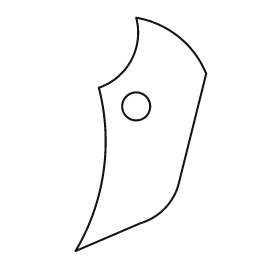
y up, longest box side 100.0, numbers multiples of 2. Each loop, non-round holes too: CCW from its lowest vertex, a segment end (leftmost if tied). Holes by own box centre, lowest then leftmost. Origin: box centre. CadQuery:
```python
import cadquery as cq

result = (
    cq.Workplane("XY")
    .moveTo(-28.0, -50.0)
    .lineTo(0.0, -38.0)
    .threePointArc((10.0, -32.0), (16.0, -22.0))
    .lineTo(28.0, 26.0)
    .threePointArc((16.0, 42.0), (-2.0, 50.0))
    .threePointArc((-4.0, 32.0), (-18.0, 20.0))
    .threePointArc((-16.0, -16.0), (-28.0, -50.0))
    .close()
    .moveTo(-2.0, 12.0)
    .circle(6.0)
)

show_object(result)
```